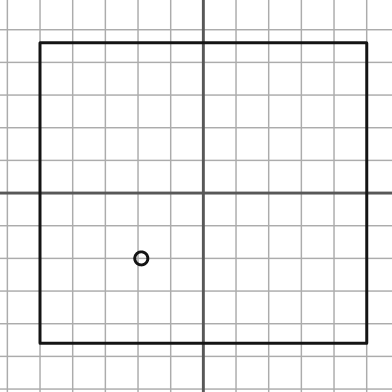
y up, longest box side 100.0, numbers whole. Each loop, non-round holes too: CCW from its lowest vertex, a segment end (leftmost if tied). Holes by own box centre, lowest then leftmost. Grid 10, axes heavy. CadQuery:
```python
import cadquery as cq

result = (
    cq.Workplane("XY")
    .moveTo(-50.0, -46.0)
    .lineTo(50.0, -46.0)
    .lineTo(50.0, 46.0)
    .lineTo(-50.0, 46.0)
    .close()
    .moveTo(-19.0, -20.0)
    .circle(2.0)
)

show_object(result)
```